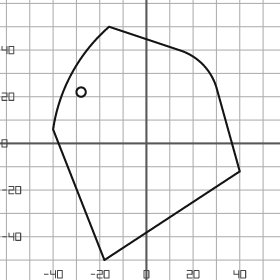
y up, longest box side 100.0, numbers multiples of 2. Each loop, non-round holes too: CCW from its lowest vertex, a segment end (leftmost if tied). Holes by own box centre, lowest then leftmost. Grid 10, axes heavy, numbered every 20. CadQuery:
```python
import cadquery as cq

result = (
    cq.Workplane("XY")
    .moveTo(-18.0, -50.0)
    .lineTo(40.0, -12.0)
    .lineTo(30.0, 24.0)
    .threePointArc((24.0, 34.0), (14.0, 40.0))
    .lineTo(-16.0, 50.0)
    .threePointArc((-32.0, 30.0), (-40.0, 6.0))
    .close()
    .moveTo(-28.0, 22.0)
    .circle(2.0)
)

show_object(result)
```